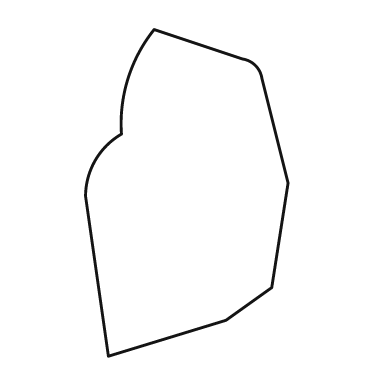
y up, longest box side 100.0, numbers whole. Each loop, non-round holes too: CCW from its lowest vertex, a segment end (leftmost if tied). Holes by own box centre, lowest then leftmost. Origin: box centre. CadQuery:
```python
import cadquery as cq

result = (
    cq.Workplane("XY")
    .moveTo(-24.0, -50.0)
    .lineTo(12.0, -39.0)
    .lineTo(26.0, -29.0)
    .lineTo(31.0, 3.0)
    .lineTo(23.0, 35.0)
    .threePointArc((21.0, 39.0), (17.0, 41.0))
    .lineTo(-10.0, 50.0)
    .threePointArc((-18.0, 35.0), (-20.0, 18.0))
    .threePointArc((-28.0, 10.0), (-31.0, -1.0))
    .close()
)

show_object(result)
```